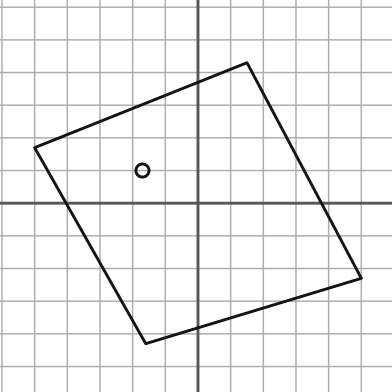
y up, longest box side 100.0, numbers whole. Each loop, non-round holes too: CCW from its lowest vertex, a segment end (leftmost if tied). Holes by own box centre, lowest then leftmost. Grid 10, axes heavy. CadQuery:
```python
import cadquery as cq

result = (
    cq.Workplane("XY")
    .moveTo(-16.0, -43.0)
    .lineTo(50.0, -23.0)
    .lineTo(15.0, 43.0)
    .lineTo(-50.0, 17.0)
    .close()
    .moveTo(-17.0, 10.0)
    .circle(2.0)
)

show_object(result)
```